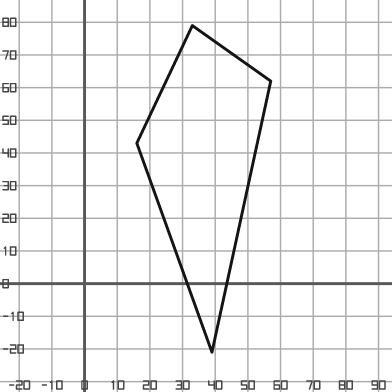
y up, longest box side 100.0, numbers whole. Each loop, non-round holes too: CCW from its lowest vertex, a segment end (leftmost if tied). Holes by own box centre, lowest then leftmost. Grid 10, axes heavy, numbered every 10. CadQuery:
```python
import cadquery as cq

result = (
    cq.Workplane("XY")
    .moveTo(39.0, -21.0)
    .lineTo(57.0, 62.0)
    .lineTo(33.0, 79.0)
    .lineTo(16.0, 43.0)
    .close()
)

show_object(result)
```